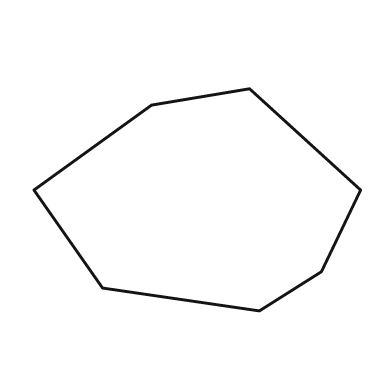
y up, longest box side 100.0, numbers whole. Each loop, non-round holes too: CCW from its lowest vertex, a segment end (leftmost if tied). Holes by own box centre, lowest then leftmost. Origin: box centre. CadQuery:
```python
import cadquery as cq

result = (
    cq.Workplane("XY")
    .moveTo(19.0, -34.0)
    .lineTo(38.0, -22.0)
    .lineTo(50.0, 3.0)
    .lineTo(16.0, 34.0)
    .lineTo(-14.0, 29.0)
    .lineTo(-50.0, 3.0)
    .lineTo(-29.0, -27.0)
    .close()
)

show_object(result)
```